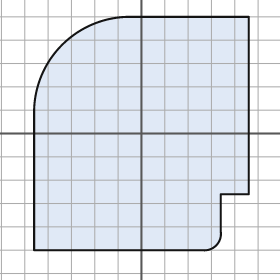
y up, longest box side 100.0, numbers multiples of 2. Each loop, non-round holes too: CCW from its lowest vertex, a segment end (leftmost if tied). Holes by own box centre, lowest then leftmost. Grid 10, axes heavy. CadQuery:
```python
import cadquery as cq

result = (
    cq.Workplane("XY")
    .moveTo(-46.0, -50.0)
    .lineTo(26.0, -50.0)
    .threePointArc((32.0, -48.0), (34.0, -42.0))
    .lineTo(34.0, -26.0)
    .lineTo(46.0, -26.0)
    .lineTo(46.0, 50.0)
    .lineTo(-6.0, 50.0)
    .threePointArc((-34.0, 38.0), (-46.0, 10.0))
    .close()
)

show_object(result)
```